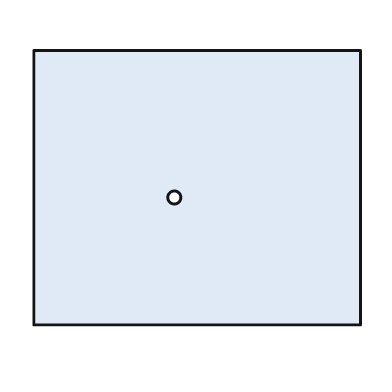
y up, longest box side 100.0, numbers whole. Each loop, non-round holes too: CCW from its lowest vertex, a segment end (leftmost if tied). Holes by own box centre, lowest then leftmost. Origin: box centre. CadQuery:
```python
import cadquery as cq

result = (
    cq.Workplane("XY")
    .moveTo(-50.0, -42.0)
    .lineTo(50.0, -42.0)
    .lineTo(50.0, 42.0)
    .lineTo(-50.0, 42.0)
    .close()
    .moveTo(-7.0, -3.0)
    .circle(2.0)
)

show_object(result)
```